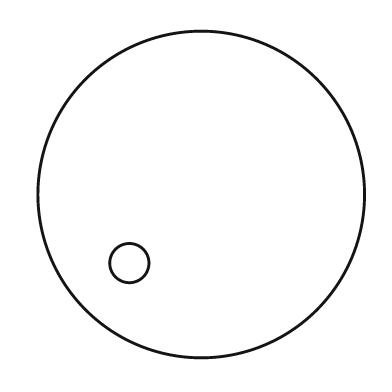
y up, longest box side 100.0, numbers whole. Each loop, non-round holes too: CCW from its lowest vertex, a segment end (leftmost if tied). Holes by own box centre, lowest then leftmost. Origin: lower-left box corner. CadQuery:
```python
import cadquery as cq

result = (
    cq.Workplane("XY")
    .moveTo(50.0, 50.0)
    .circle(50.0)
    .moveTo(28.0, 29.0)
    .circle(6.0)
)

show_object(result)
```